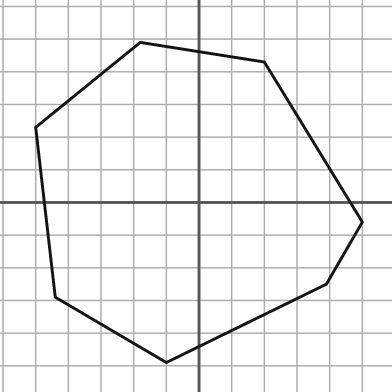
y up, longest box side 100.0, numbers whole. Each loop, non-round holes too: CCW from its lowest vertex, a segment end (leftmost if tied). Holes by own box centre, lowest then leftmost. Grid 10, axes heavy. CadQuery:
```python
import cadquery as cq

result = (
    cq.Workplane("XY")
    .moveTo(-10.0, -49.0)
    .lineTo(39.0, -25.0)
    .lineTo(50.0, -6.0)
    .lineTo(20.0, 43.0)
    .lineTo(-18.0, 49.0)
    .lineTo(-50.0, 23.0)
    .lineTo(-44.0, -29.0)
    .close()
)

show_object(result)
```